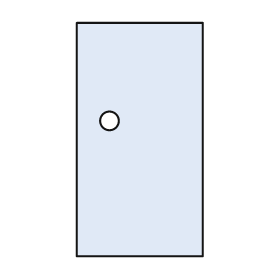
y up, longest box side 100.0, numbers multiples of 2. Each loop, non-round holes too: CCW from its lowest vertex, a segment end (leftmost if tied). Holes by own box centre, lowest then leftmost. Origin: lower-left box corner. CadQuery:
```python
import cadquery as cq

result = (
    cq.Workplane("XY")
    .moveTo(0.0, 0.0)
    .lineTo(54.0, 0.0)
    .lineTo(54.0, 100.0)
    .lineTo(0.0, 100.0)
    .close()
    .moveTo(14.0, 58.0)
    .circle(4.0)
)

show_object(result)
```